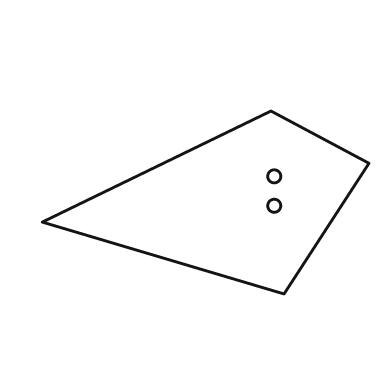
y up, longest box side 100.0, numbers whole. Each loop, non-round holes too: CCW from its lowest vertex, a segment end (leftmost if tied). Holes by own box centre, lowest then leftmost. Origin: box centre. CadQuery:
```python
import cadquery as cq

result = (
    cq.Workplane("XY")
    .moveTo(24.0, -28.0)
    .lineTo(50.0, 12.0)
    .lineTo(20.0, 28.0)
    .lineTo(-50.0, -6.0)
    .close()
    .moveTo(21.0, -1.0)
    .circle(2.0)
    .moveTo(21.0, 8.0)
    .circle(2.0)
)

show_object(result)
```